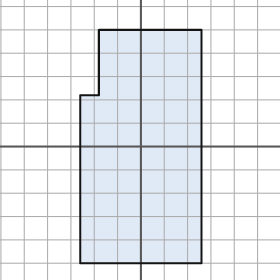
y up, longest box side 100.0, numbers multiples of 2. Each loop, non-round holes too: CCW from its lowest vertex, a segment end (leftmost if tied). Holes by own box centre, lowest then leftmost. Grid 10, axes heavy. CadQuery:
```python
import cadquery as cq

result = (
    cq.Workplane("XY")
    .moveTo(-26.0, -50.0)
    .lineTo(26.0, -50.0)
    .lineTo(26.0, 50.0)
    .lineTo(-18.0, 50.0)
    .lineTo(-18.0, 22.0)
    .lineTo(-26.0, 22.0)
    .close()
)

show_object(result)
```